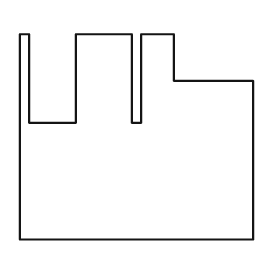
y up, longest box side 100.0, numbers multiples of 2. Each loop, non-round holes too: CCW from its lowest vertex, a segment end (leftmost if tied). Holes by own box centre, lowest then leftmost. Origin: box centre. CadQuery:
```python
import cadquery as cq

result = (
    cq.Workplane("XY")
    .moveTo(-50.0, -44.0)
    .lineTo(50.0, -44.0)
    .lineTo(50.0, 24.0)
    .lineTo(16.0, 24.0)
    .lineTo(16.0, 44.0)
    .lineTo(2.0, 44.0)
    .lineTo(2.0, 6.0)
    .lineTo(-2.0, 6.0)
    .lineTo(-2.0, 44.0)
    .lineTo(-26.0, 44.0)
    .lineTo(-26.0, 6.0)
    .lineTo(-46.0, 6.0)
    .lineTo(-46.0, 44.0)
    .lineTo(-50.0, 44.0)
    .close()
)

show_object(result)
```